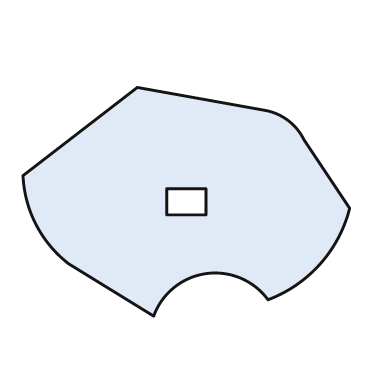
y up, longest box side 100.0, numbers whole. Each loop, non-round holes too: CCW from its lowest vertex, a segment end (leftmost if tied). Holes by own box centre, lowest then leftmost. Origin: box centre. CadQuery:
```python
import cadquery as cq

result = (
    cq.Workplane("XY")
    .moveTo(-10.0, -35.0)
    .threePointArc((6.0, -22.0), (25.0, -30.0))
    .threePointArc((41.0, -19.0), (50.0, -2.0))
    .lineTo(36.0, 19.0)
    .threePointArc((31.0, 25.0), (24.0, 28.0))
    .lineTo(-15.0, 35.0)
    .lineTo(-50.0, 8.0)
    .threePointArc((-46.0, -7.0), (-36.0, -19.0))
    .close()
    .moveTo(-6.0, -4.0)
    .lineTo(6.0, -4.0)
    .lineTo(6.0, 4.0)
    .lineTo(-6.0, 4.0)
    .close()
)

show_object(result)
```